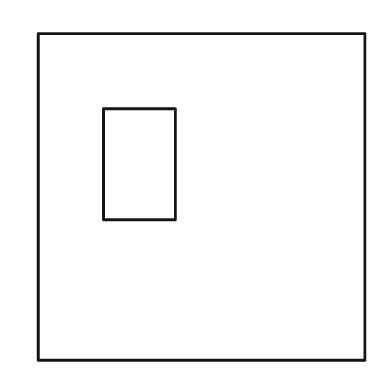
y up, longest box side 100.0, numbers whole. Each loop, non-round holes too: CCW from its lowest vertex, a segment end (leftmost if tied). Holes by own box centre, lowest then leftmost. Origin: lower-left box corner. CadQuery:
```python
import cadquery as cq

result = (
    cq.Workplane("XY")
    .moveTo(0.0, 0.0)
    .lineTo(100.0, 0.0)
    .lineTo(100.0, 100.0)
    .lineTo(0.0, 100.0)
    .close()
    .moveTo(20.0, 43.0)
    .lineTo(42.0, 43.0)
    .lineTo(42.0, 77.0)
    .lineTo(20.0, 77.0)
    .close()
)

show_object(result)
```